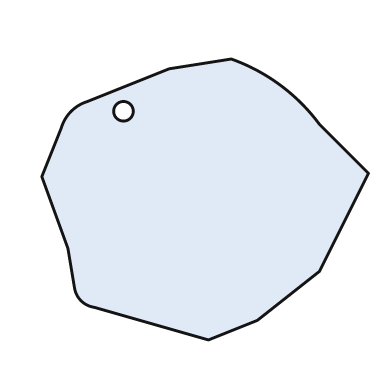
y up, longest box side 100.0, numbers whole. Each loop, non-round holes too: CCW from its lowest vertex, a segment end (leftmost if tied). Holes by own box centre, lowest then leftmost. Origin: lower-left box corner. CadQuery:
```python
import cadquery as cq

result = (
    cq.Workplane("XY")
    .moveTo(51.0, 0.0)
    .lineTo(66.0, 6.0)
    .lineTo(85.0, 21.0)
    .lineTo(100.0, 51.0)
    .lineTo(85.0, 66.0)
    .threePointArc((73.0, 78.0), (58.0, 86.0))
    .lineTo(39.0, 83.0)
    .lineTo(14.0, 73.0)
    .threePointArc((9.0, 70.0), (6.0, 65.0))
    .lineTo(0.0, 50.0)
    .lineTo(8.0, 28.0)
    .lineTo(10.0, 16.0)
    .threePointArc((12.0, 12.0), (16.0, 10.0))
    .close()
    .moveTo(25.0, 70.0)
    .circle(3.0)
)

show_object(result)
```